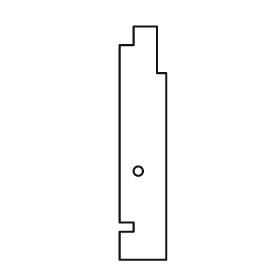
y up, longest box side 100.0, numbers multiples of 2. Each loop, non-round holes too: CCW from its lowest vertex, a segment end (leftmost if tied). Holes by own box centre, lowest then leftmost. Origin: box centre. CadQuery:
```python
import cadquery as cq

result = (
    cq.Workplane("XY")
    .moveTo(-10.0, -50.0)
    .lineTo(10.0, -50.0)
    .lineTo(10.0, 30.0)
    .lineTo(6.0, 30.0)
    .lineTo(6.0, 50.0)
    .lineTo(-4.0, 50.0)
    .lineTo(-4.0, 42.0)
    .lineTo(-10.0, 42.0)
    .lineTo(-10.0, -34.0)
    .lineTo(-4.0, -34.0)
    .lineTo(-4.0, -38.0)
    .lineTo(-10.0, -38.0)
    .close()
    .moveTo(-2.0, -12.0)
    .circle(2.0)
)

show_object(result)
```